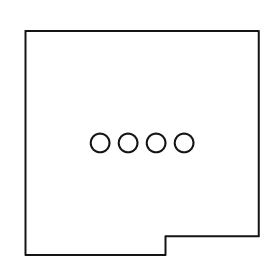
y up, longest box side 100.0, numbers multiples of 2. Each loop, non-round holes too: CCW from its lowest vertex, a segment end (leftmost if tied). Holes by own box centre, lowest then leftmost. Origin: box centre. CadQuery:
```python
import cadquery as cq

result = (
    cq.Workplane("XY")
    .moveTo(-50.0, -48.0)
    .lineTo(10.0, -48.0)
    .lineTo(10.0, -40.0)
    .lineTo(50.0, -40.0)
    .lineTo(50.0, 48.0)
    .lineTo(-50.0, 48.0)
    .close()
    .moveTo(-18.0, 0.0)
    .circle(4.0)
    .moveTo(-6.0, 0.0)
    .circle(4.0)
    .moveTo(6.0, 0.0)
    .circle(4.0)
    .moveTo(18.0, 0.0)
    .circle(4.0)
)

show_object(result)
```